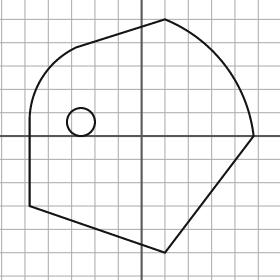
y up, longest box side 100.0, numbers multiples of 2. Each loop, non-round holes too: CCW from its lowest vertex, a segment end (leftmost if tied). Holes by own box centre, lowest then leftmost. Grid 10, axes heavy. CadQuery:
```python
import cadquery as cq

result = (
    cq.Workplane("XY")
    .moveTo(10.0, -50.0)
    .lineTo(48.0, 0.0)
    .threePointArc((36.0, 30.0), (10.0, 50.0))
    .lineTo(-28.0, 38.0)
    .threePointArc((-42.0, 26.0), (-48.0, 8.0))
    .lineTo(-48.0, -30.0)
    .close()
    .moveTo(-26.0, 6.0)
    .circle(6.0)
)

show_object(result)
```